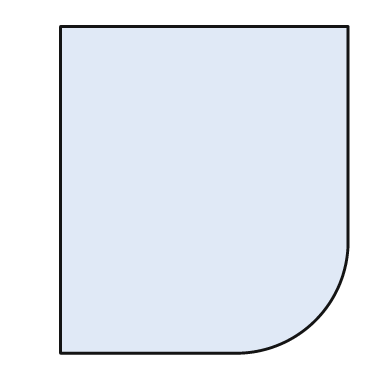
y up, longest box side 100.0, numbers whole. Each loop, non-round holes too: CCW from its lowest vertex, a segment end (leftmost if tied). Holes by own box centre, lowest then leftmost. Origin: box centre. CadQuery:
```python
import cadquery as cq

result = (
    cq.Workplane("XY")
    .moveTo(-44.0, -50.0)
    .lineTo(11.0, -50.0)
    .threePointArc((34.0, -40.0), (44.0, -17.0))
    .lineTo(44.0, 50.0)
    .lineTo(-44.0, 50.0)
    .close()
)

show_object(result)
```